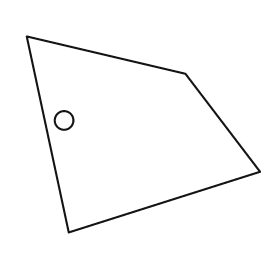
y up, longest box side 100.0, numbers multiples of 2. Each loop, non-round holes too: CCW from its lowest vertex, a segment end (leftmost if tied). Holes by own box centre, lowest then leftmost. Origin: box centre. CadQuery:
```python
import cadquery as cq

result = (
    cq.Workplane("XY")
    .moveTo(-32.0, -42.0)
    .lineTo(50.0, -16.0)
    .lineTo(18.0, 26.0)
    .lineTo(-50.0, 42.0)
    .close()
    .moveTo(-34.0, 6.0)
    .circle(4.0)
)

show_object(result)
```